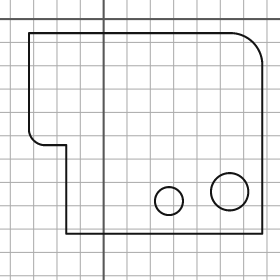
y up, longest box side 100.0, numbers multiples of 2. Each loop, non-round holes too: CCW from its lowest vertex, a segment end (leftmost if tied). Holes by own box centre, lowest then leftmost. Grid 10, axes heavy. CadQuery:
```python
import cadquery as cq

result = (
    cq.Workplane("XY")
    .moveTo(-16.0, -92.0)
    .lineTo(68.0, -92.0)
    .lineTo(68.0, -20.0)
    .threePointArc((64.0, -10.0), (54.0, -6.0))
    .lineTo(-32.0, -6.0)
    .lineTo(-32.0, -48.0)
    .threePointArc((-30.0, -52.0), (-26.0, -54.0))
    .lineTo(-16.0, -54.0)
    .close()
    .moveTo(28.0, -78.0)
    .circle(6.0)
    .moveTo(54.0, -74.0)
    .circle(8.0)
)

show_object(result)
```